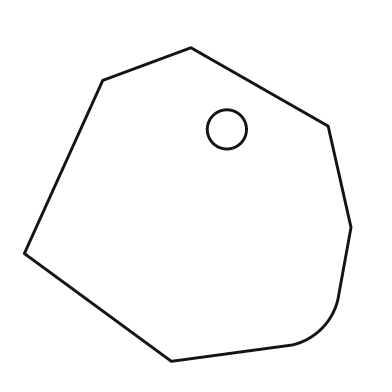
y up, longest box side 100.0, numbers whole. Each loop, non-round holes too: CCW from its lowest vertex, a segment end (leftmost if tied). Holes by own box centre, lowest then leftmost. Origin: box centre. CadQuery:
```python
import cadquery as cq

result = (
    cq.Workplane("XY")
    .moveTo(-5.0, -48.0)
    .lineTo(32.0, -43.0)
    .threePointArc((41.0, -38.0), (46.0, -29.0))
    .lineTo(50.0, -7.0)
    .lineTo(43.0, 24.0)
    .lineTo(1.0, 48.0)
    .lineTo(-26.0, 38.0)
    .lineTo(-50.0, -15.0)
    .close()
    .moveTo(12.0, 23.0)
    .circle(6.0)
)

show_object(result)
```